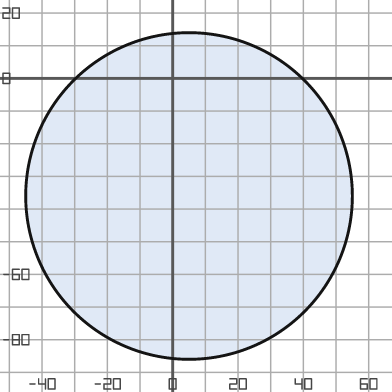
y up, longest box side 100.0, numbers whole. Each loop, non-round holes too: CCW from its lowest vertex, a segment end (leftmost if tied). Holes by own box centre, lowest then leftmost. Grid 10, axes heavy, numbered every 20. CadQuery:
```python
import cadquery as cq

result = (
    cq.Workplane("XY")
    .moveTo(5.0, -36.0)
    .circle(50.0)
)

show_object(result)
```